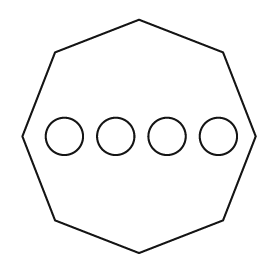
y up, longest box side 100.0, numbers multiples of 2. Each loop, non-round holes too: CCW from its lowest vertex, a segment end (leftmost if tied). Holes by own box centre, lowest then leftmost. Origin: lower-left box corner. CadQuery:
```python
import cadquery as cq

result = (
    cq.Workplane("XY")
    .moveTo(50.0, 0.0)
    .lineTo(86.0, 14.0)
    .lineTo(100.0, 50.0)
    .lineTo(86.0, 86.0)
    .lineTo(50.0, 100.0)
    .lineTo(14.0, 86.0)
    .lineTo(0.0, 50.0)
    .lineTo(14.0, 14.0)
    .close()
    .moveTo(18.0, 50.0)
    .circle(8.0)
    .moveTo(40.0, 50.0)
    .circle(8.0)
    .moveTo(62.0, 50.0)
    .circle(8.0)
    .moveTo(84.0, 50.0)
    .circle(8.0)
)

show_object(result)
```